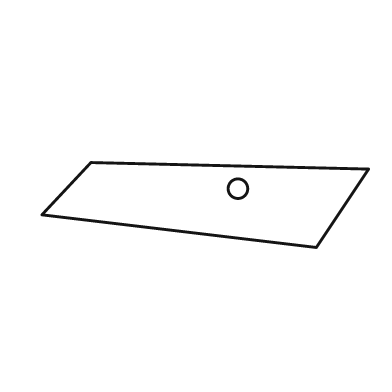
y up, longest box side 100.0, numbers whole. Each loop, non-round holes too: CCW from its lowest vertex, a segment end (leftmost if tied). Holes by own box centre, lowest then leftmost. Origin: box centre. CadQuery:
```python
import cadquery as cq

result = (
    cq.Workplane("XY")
    .moveTo(34.0, -13.0)
    .lineTo(50.0, 11.0)
    .lineTo(-35.0, 13.0)
    .lineTo(-50.0, -3.0)
    .close()
    .moveTo(10.0, 5.0)
    .circle(3.0)
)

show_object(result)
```